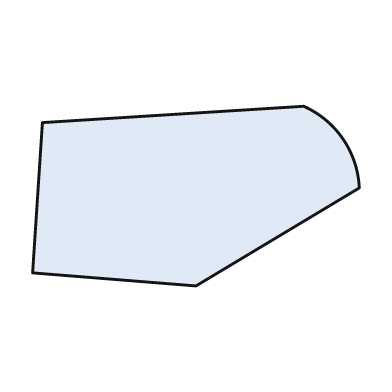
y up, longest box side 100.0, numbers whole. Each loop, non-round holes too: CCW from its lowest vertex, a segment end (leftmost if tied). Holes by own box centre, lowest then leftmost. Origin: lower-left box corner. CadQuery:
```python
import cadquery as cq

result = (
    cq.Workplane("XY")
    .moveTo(50.0, 0.0)
    .lineTo(100.0, 30.0)
    .threePointArc((95.0, 45.0), (83.0, 55.0))
    .lineTo(3.0, 50.0)
    .lineTo(0.0, 4.0)
    .close()
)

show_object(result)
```